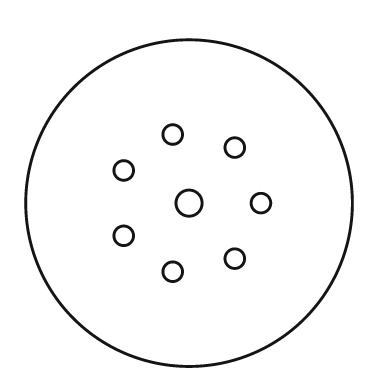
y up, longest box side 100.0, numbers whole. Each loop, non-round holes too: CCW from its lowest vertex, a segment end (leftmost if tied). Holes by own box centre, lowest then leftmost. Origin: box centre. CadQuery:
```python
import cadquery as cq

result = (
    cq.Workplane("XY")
    .moveTo(0.0, 0.0)
    .circle(50.0)
    .moveTo(-5.0, -21.0)
    .circle(3.0)
    .moveTo(14.0, -17.0)
    .circle(3.0)
    .moveTo(-20.0, -10.0)
    .circle(3.0)
    .moveTo(0.0, 0.0)
    .circle(4.0)
    .moveTo(22.0, 0.0)
    .circle(3.0)
    .moveTo(-20.0, 10.0)
    .circle(3.0)
    .moveTo(14.0, 17.0)
    .circle(3.0)
    .moveTo(-5.0, 21.0)
    .circle(3.0)
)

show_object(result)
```